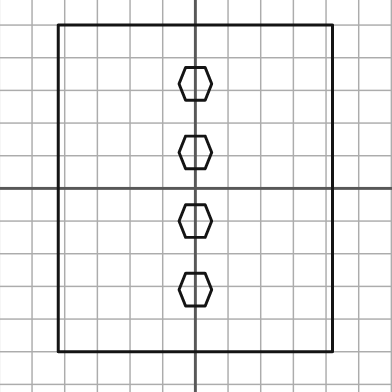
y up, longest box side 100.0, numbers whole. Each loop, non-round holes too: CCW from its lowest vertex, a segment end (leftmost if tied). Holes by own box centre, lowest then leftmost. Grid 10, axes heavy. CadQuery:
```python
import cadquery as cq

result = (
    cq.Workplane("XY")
    .moveTo(-42.0, -50.0)
    .lineTo(42.0, -50.0)
    .lineTo(42.0, 50.0)
    .lineTo(-42.0, 50.0)
    .close()
    .moveTo(-3.0, -36.0)
    .lineTo(3.0, -36.0)
    .lineTo(5.0, -31.0)
    .lineTo(3.0, -26.0)
    .lineTo(-3.0, -26.0)
    .lineTo(-5.0, -31.0)
    .close()
    .moveTo(-3.0, -15.0)
    .lineTo(3.0, -15.0)
    .lineTo(5.0, -10.0)
    .lineTo(3.0, -5.0)
    .lineTo(-3.0, -5.0)
    .lineTo(-5.0, -10.0)
    .close()
    .moveTo(-3.0, 6.0)
    .lineTo(3.0, 6.0)
    .lineTo(5.0, 11.0)
    .lineTo(3.0, 16.0)
    .lineTo(-3.0, 16.0)
    .lineTo(-5.0, 11.0)
    .close()
    .moveTo(-3.0, 27.0)
    .lineTo(3.0, 27.0)
    .lineTo(5.0, 32.0)
    .lineTo(3.0, 37.0)
    .lineTo(-3.0, 37.0)
    .lineTo(-5.0, 32.0)
    .close()
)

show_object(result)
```